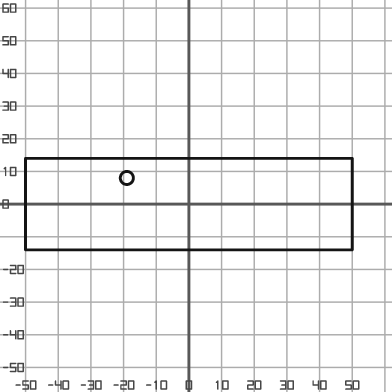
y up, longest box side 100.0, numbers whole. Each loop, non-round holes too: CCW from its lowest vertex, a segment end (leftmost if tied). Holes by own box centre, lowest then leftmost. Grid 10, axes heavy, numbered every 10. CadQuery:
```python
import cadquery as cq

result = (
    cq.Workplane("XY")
    .moveTo(-50.0, -14.0)
    .lineTo(50.0, -14.0)
    .lineTo(50.0, 14.0)
    .lineTo(-50.0, 14.0)
    .close()
    .moveTo(-19.0, 8.0)
    .circle(2.0)
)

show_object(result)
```